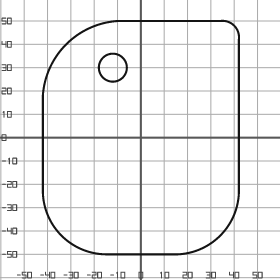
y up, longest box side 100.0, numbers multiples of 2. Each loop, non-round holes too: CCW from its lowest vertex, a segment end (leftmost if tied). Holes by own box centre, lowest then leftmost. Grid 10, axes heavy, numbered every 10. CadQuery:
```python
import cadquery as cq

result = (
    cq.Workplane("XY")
    .moveTo(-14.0, -50.0)
    .lineTo(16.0, -50.0)
    .threePointArc((34.0, -42.0), (42.0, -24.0))
    .lineTo(42.0, 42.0)
    .threePointArc((40.0, 48.0), (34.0, 50.0))
    .lineTo(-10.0, 50.0)
    .threePointArc((-32.0, 40.0), (-42.0, 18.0))
    .lineTo(-42.0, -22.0)
    .threePointArc((-34.0, -42.0), (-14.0, -50.0))
    .close()
    .moveTo(-12.0, 30.0)
    .circle(6.0)
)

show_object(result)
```